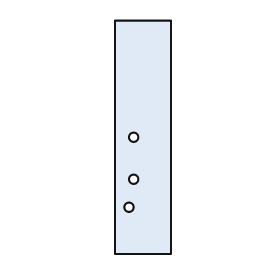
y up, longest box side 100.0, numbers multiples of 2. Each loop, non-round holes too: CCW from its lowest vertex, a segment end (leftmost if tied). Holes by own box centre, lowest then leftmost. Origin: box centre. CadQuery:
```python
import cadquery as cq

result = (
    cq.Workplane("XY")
    .moveTo(-12.0, -50.0)
    .lineTo(12.0, -50.0)
    .lineTo(12.0, 50.0)
    .lineTo(-12.0, 50.0)
    .close()
    .moveTo(-6.0, -30.0)
    .circle(2.0)
    .moveTo(-4.0, -18.0)
    .circle(2.0)
    .moveTo(-4.0, 0.0)
    .circle(2.0)
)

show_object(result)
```